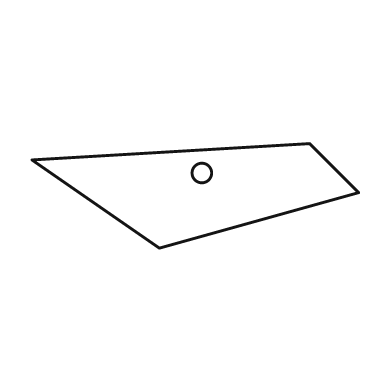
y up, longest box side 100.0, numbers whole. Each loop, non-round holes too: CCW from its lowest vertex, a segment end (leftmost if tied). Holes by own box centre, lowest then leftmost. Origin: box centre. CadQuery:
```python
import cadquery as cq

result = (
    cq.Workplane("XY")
    .moveTo(-11.0, -16.0)
    .lineTo(50.0, 1.0)
    .lineTo(35.0, 16.0)
    .lineTo(-50.0, 11.0)
    .close()
    .moveTo(2.0, 7.0)
    .circle(3.0)
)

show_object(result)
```